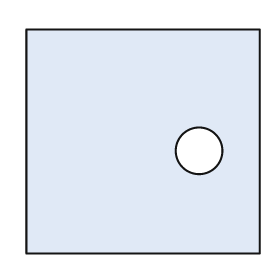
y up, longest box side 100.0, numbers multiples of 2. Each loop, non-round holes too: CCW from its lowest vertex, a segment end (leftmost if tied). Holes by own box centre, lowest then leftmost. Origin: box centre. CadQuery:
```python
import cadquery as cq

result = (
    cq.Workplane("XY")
    .moveTo(-50.0, -48.0)
    .lineTo(50.0, -48.0)
    .lineTo(50.0, 48.0)
    .lineTo(-50.0, 48.0)
    .close()
    .moveTo(24.0, -4.0)
    .circle(10.0)
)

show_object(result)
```